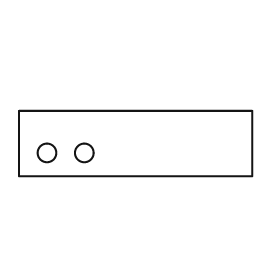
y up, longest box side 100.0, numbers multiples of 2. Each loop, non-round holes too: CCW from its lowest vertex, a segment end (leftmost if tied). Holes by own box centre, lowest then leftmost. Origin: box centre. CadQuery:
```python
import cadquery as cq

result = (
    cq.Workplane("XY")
    .moveTo(-50.0, -14.0)
    .lineTo(50.0, -14.0)
    .lineTo(50.0, 14.0)
    .lineTo(-50.0, 14.0)
    .close()
    .moveTo(-38.0, -4.0)
    .circle(4.0)
    .moveTo(-22.0, -4.0)
    .circle(4.0)
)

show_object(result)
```